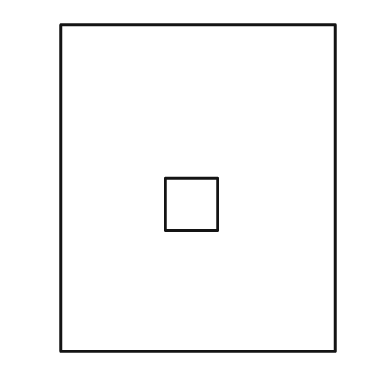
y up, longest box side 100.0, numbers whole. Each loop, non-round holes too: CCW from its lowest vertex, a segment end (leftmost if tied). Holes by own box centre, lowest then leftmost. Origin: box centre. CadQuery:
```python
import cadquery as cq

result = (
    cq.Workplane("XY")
    .moveTo(-42.0, -50.0)
    .lineTo(42.0, -50.0)
    .lineTo(42.0, 50.0)
    .lineTo(-42.0, 50.0)
    .close()
    .moveTo(-10.0, -13.0)
    .lineTo(6.0, -13.0)
    .lineTo(6.0, 3.0)
    .lineTo(-10.0, 3.0)
    .close()
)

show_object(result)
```